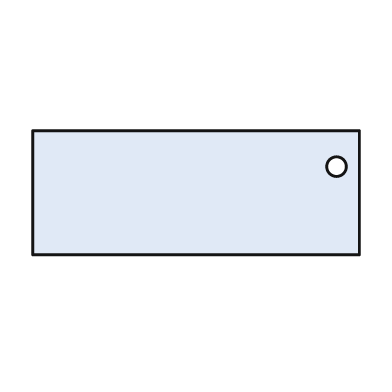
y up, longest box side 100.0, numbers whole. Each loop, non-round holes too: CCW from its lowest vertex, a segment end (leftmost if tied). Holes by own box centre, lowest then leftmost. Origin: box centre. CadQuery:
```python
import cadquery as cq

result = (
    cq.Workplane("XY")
    .moveTo(-50.0, -19.0)
    .lineTo(50.0, -19.0)
    .lineTo(50.0, 19.0)
    .lineTo(-50.0, 19.0)
    .close()
    .moveTo(43.0, 8.0)
    .circle(3.0)
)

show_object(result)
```